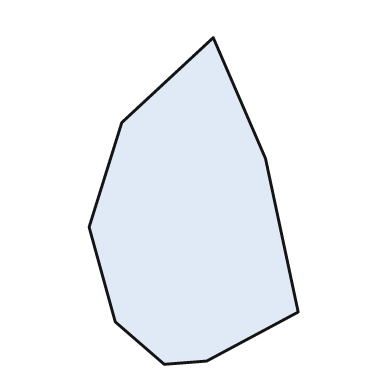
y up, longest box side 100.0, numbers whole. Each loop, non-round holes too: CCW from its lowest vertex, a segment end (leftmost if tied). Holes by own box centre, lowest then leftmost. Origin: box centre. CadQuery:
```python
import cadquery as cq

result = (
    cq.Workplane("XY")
    .moveTo(-9.0, -50.0)
    .lineTo(4.0, -49.0)
    .lineTo(32.0, -34.0)
    .lineTo(22.0, 13.0)
    .lineTo(6.0, 50.0)
    .lineTo(-22.0, 24.0)
    .lineTo(-32.0, -8.0)
    .lineTo(-24.0, -37.0)
    .close()
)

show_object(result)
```